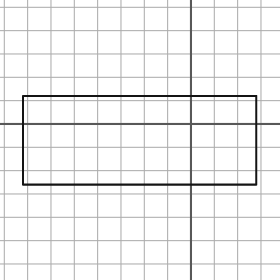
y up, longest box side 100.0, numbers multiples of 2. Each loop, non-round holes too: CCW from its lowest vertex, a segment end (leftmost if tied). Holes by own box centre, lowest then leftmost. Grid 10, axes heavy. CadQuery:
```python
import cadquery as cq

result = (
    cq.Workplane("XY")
    .moveTo(-72.0, -26.0)
    .lineTo(28.0, -26.0)
    .lineTo(28.0, 12.0)
    .lineTo(-72.0, 12.0)
    .close()
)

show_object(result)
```